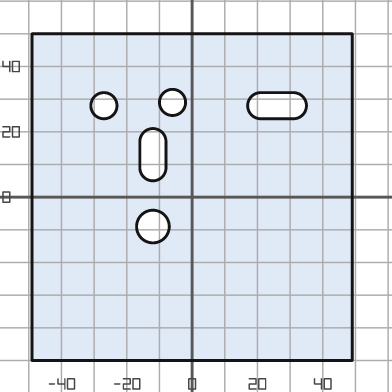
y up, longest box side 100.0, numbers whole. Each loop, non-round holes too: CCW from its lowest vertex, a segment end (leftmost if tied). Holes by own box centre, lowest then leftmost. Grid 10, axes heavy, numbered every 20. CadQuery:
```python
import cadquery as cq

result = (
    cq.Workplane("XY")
    .moveTo(-49.0, -50.0)
    .lineTo(49.0, -50.0)
    .lineTo(49.0, 50.0)
    .lineTo(-49.0, 50.0)
    .close()
    .moveTo(-12.0, -9.0)
    .circle(5.0)
    .moveTo(-16.0, 9.0)
    .threePointArc((-12.0, 5.0), (-8.0, 9.0))
    .lineTo(-8.0, 17.0)
    .threePointArc((-12.0, 21.0), (-16.0, 17.0))
    .close()
    .moveTo(-27.0, 28.0)
    .circle(4.0)
    .moveTo(21.0, 24.0)
    .lineTo(31.0, 24.0)
    .threePointArc((35.0, 28.0), (31.0, 32.0))
    .lineTo(21.0, 32.0)
    .threePointArc((17.0, 28.0), (21.0, 24.0))
    .close()
    .moveTo(-6.0, 29.0)
    .circle(4.0)
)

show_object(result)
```